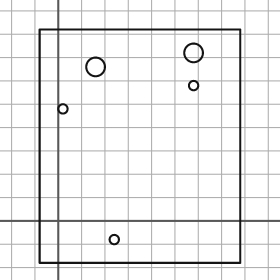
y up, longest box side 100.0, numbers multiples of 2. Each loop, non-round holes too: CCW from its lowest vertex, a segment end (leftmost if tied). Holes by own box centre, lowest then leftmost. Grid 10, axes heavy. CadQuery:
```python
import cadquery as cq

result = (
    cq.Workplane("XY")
    .moveTo(-8.0, -18.0)
    .lineTo(78.0, -18.0)
    .lineTo(78.0, 82.0)
    .lineTo(-8.0, 82.0)
    .close()
    .moveTo(24.0, -8.0)
    .circle(2.0)
    .moveTo(2.0, 48.0)
    .circle(2.0)
    .moveTo(58.0, 58.0)
    .circle(2.0)
    .moveTo(16.0, 66.0)
    .circle(4.0)
    .moveTo(58.0, 72.0)
    .circle(4.0)
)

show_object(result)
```